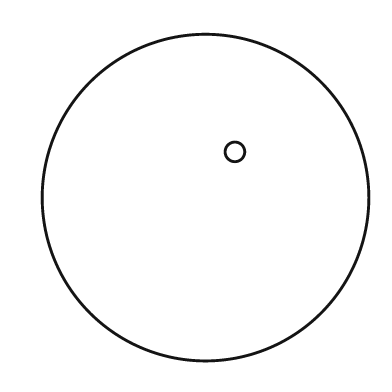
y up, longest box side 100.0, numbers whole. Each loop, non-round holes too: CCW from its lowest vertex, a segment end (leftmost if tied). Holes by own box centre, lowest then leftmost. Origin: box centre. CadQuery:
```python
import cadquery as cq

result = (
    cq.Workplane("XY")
    .moveTo(0.0, 0.0)
    .circle(50.0)
    .moveTo(9.0, 14.0)
    .circle(3.0)
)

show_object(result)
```